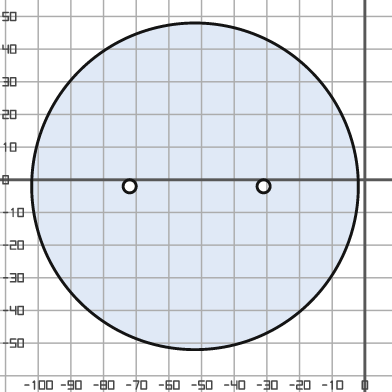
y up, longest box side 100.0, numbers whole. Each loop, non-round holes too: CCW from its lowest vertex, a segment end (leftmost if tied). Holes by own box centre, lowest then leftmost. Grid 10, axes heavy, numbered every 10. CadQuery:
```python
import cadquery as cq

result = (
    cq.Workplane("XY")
    .moveTo(-52.0, -2.0)
    .circle(50.0)
    .moveTo(-72.0, -2.0)
    .circle(2.0)
    .moveTo(-31.0, -2.0)
    .circle(2.0)
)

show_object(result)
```